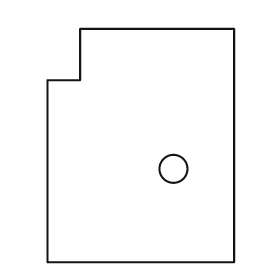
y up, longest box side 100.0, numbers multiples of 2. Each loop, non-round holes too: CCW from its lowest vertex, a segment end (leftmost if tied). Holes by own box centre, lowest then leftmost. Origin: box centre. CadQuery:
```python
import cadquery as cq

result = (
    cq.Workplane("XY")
    .moveTo(-40.0, -50.0)
    .lineTo(40.0, -50.0)
    .lineTo(40.0, 50.0)
    .lineTo(-26.0, 50.0)
    .lineTo(-26.0, 28.0)
    .lineTo(-40.0, 28.0)
    .close()
    .moveTo(14.0, -10.0)
    .circle(6.0)
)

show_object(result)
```